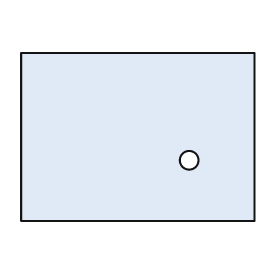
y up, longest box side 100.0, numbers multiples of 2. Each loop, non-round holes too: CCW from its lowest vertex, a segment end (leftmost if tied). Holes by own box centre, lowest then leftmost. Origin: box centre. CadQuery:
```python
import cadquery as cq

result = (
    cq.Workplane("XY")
    .moveTo(-50.0, -36.0)
    .lineTo(50.0, -36.0)
    .lineTo(50.0, 36.0)
    .lineTo(-50.0, 36.0)
    .close()
    .moveTo(22.0, -10.0)
    .circle(4.0)
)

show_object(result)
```